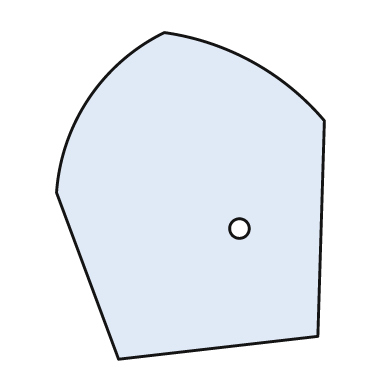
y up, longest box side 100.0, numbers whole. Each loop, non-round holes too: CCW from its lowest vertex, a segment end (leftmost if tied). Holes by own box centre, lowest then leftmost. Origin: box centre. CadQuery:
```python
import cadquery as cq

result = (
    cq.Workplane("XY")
    .moveTo(-22.0, -50.0)
    .lineTo(39.0, -43.0)
    .lineTo(41.0, 23.0)
    .threePointArc((19.0, 41.0), (-8.0, 50.0))
    .threePointArc((-31.0, 30.0), (-41.0, 1.0))
    .close()
    .moveTo(15.0, -10.0)
    .circle(3.0)
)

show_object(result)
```